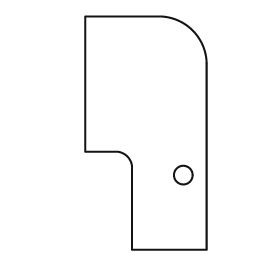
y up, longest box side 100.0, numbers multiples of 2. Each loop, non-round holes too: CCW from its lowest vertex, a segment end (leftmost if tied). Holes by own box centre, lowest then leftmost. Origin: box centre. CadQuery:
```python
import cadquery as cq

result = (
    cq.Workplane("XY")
    .moveTo(-6.0, -50.0)
    .lineTo(26.0, -50.0)
    .lineTo(26.0, 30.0)
    .threePointArc((20.0, 44.0), (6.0, 50.0))
    .lineTo(-26.0, 50.0)
    .lineTo(-26.0, -8.0)
    .lineTo(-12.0, -8.0)
    .threePointArc((-8.0, -10.0), (-6.0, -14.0))
    .close()
    .moveTo(16.0, -18.0)
    .circle(4.0)
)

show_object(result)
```